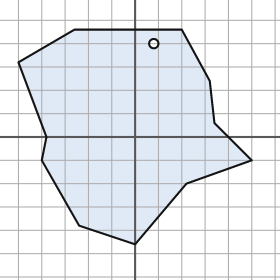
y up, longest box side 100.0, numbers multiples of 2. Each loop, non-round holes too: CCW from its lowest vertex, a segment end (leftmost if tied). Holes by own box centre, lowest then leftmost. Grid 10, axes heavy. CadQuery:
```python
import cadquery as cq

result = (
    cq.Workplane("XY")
    .moveTo(0.0, -46.0)
    .lineTo(22.0, -20.0)
    .lineTo(50.0, -10.0)
    .lineTo(34.0, 6.0)
    .lineTo(32.0, 24.0)
    .lineTo(20.0, 46.0)
    .lineTo(-26.0, 46.0)
    .lineTo(-50.0, 32.0)
    .lineTo(-38.0, 0.0)
    .lineTo(-40.0, -10.0)
    .lineTo(-24.0, -38.0)
    .close()
    .moveTo(8.0, 40.0)
    .circle(2.0)
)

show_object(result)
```